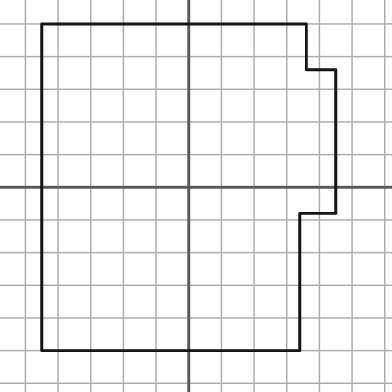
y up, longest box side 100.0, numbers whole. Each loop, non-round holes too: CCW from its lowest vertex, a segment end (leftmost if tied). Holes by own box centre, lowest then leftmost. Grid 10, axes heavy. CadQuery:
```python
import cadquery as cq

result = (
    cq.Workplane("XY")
    .moveTo(-45.0, -50.0)
    .lineTo(34.0, -50.0)
    .lineTo(34.0, -8.0)
    .lineTo(45.0, -8.0)
    .lineTo(45.0, 36.0)
    .lineTo(36.0, 36.0)
    .lineTo(36.0, 50.0)
    .lineTo(-45.0, 50.0)
    .close()
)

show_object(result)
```